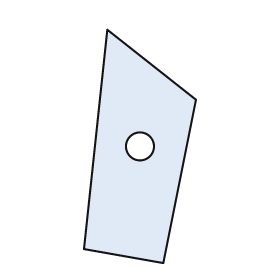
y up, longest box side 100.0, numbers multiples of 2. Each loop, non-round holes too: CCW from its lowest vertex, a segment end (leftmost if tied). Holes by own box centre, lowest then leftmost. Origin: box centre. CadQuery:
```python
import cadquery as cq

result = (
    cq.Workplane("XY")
    .moveTo(10.0, -50.0)
    .lineTo(24.0, 20.0)
    .lineTo(-14.0, 50.0)
    .lineTo(-24.0, -44.0)
    .close()
    .moveTo(0.0, 0.0)
    .circle(6.0)
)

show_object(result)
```